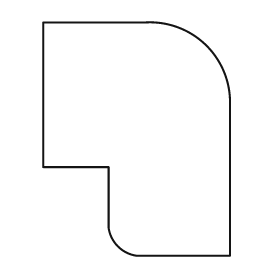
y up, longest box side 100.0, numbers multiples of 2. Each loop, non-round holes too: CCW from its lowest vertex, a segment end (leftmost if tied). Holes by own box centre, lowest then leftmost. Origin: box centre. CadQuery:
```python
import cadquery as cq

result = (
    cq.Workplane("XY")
    .moveTo(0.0, -50.0)
    .lineTo(40.0, -50.0)
    .lineTo(40.0, 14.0)
    .threePointArc((30.0, 40.0), (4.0, 50.0))
    .lineTo(-40.0, 50.0)
    .lineTo(-40.0, -12.0)
    .lineTo(-12.0, -12.0)
    .lineTo(-12.0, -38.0)
    .threePointArc((-8.0, -46.0), (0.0, -50.0))
    .close()
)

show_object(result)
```